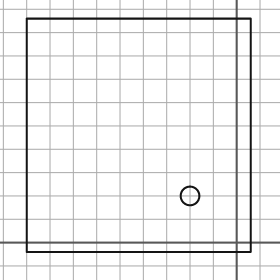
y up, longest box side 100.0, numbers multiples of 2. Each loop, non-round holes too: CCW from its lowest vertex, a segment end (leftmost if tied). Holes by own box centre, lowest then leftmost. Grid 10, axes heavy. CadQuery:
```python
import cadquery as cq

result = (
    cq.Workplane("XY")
    .moveTo(-90.0, -4.0)
    .lineTo(6.0, -4.0)
    .lineTo(6.0, 96.0)
    .lineTo(-90.0, 96.0)
    .close()
    .moveTo(-20.0, 20.0)
    .circle(4.0)
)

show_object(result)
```